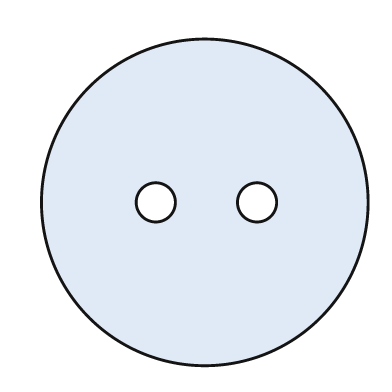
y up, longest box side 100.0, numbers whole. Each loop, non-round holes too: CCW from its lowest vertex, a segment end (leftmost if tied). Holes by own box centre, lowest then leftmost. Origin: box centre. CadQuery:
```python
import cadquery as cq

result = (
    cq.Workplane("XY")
    .moveTo(0.0, 0.0)
    .circle(50.0)
    .moveTo(-15.0, 0.0)
    .circle(6.0)
    .moveTo(16.0, 0.0)
    .circle(6.0)
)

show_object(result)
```